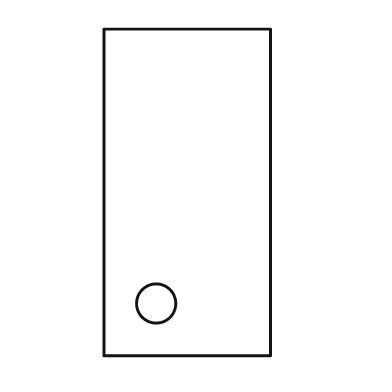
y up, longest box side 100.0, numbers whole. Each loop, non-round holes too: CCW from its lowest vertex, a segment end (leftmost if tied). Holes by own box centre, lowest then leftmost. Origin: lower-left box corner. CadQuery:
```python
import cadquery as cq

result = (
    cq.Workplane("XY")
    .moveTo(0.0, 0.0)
    .lineTo(51.0, 0.0)
    .lineTo(51.0, 100.0)
    .lineTo(0.0, 100.0)
    .close()
    .moveTo(16.0, 16.0)
    .circle(6.0)
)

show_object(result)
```